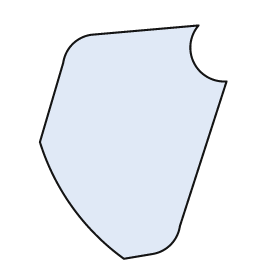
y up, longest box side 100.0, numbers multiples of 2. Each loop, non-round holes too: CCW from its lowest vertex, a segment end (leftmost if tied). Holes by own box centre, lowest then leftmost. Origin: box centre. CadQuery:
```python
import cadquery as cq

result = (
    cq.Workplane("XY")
    .moveTo(-4.0, -50.0)
    .lineTo(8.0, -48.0)
    .threePointArc((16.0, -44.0), (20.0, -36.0))
    .lineTo(40.0, 26.0)
    .threePointArc((26.0, 34.0), (28.0, 50.0))
    .lineTo(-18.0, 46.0)
    .threePointArc((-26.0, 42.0), (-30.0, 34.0))
    .lineTo(-40.0, 0.0)
    .threePointArc((-26.0, -28.0), (-4.0, -50.0))
    .close()
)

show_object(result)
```